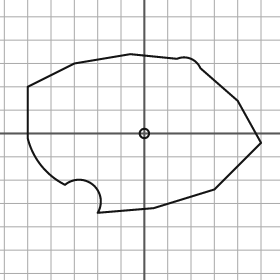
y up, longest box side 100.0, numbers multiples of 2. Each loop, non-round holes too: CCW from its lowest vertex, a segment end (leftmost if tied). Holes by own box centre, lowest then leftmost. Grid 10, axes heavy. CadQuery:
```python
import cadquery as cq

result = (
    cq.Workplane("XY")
    .moveTo(-20.0, -34.0)
    .lineTo(4.0, -32.0)
    .lineTo(30.0, -24.0)
    .lineTo(50.0, -4.0)
    .lineTo(40.0, 14.0)
    .lineTo(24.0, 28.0)
    .threePointArc((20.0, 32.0), (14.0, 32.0))
    .lineTo(-6.0, 34.0)
    .lineTo(-30.0, 30.0)
    .lineTo(-50.0, 20.0)
    .lineTo(-50.0, -2.0)
    .threePointArc((-44.0, -14.0), (-34.0, -22.0))
    .threePointArc((-22.0, -22.0), (-20.0, -34.0))
    .close()
    .moveTo(0.0, 0.0)
    .circle(2.0)
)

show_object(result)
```